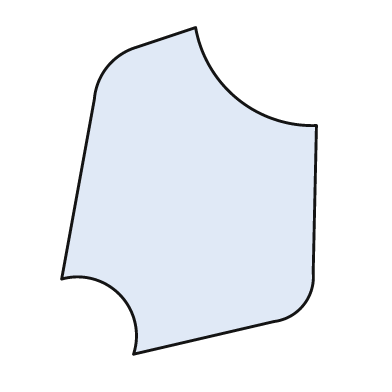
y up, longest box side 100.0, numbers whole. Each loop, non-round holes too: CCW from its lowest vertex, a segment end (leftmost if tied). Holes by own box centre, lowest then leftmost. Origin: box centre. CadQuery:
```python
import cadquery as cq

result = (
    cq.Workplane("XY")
    .moveTo(-17.0, -50.0)
    .lineTo(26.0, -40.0)
    .threePointArc((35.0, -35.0), (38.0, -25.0))
    .lineTo(39.0, 20.0)
    .threePointArc((15.0, 28.0), (2.0, 50.0))
    .lineTo(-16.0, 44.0)
    .threePointArc((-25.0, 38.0), (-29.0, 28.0))
    .lineTo(-39.0, -27.0)
    .threePointArc((-21.0, -32.0), (-17.0, -50.0))
    .close()
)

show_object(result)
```